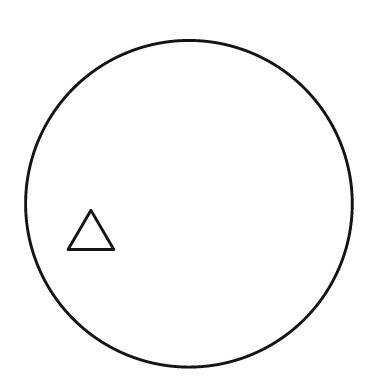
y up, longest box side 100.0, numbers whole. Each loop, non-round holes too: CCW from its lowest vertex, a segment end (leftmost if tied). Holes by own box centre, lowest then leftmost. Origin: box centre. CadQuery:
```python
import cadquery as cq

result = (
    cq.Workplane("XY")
    .moveTo(0.0, 0.0)
    .circle(50.0)
    .moveTo(-37.0, -14.0)
    .lineTo(-23.0, -14.0)
    .lineTo(-30.0, -2.0)
    .close()
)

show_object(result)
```